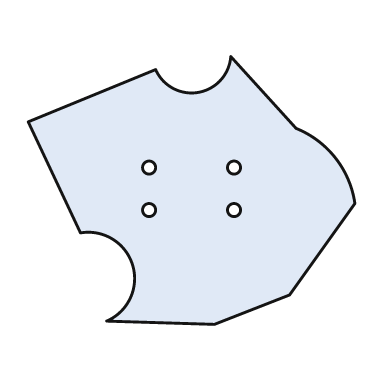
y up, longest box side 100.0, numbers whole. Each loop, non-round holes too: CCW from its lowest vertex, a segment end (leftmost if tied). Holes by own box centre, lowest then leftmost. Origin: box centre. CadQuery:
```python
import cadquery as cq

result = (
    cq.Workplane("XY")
    .moveTo(7.0, -41.0)
    .lineTo(30.0, -32.0)
    .lineTo(50.0, -4.0)
    .threePointArc((44.0, 10.0), (32.0, 19.0))
    .lineTo(12.0, 41.0)
    .threePointArc((2.0, 30.0), (-11.0, 37.0))
    .lineTo(-50.0, 21.0)
    .lineTo(-34.0, -13.0)
    .threePointArc((-18.0, -23.0), (-26.0, -40.0))
    .close()
    .moveTo(-13.0, -6.0)
    .circle(2.0)
    .moveTo(13.0, -6.0)
    .circle(2.0)
    .moveTo(-13.0, 7.0)
    .circle(2.0)
    .moveTo(13.0, 7.0)
    .circle(2.0)
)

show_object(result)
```